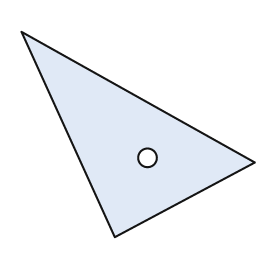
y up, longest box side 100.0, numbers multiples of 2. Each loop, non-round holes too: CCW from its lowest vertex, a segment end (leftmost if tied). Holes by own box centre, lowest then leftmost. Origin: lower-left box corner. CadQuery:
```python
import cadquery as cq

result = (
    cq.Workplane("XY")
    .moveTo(40.0, 0.0)
    .lineTo(100.0, 32.0)
    .lineTo(0.0, 88.0)
    .close()
    .moveTo(54.0, 34.0)
    .circle(4.0)
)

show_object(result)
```